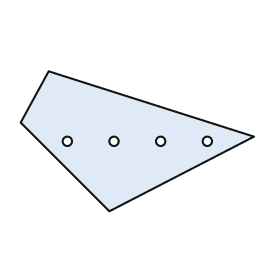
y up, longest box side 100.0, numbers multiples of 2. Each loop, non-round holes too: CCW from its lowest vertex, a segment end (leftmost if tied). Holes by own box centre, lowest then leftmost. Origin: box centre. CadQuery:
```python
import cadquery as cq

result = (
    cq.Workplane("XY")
    .moveTo(-12.0, -30.0)
    .lineTo(50.0, 2.0)
    .lineTo(-38.0, 30.0)
    .lineTo(-50.0, 8.0)
    .close()
    .moveTo(-30.0, 0.0)
    .circle(2.0)
    .moveTo(-10.0, 0.0)
    .circle(2.0)
    .moveTo(10.0, 0.0)
    .circle(2.0)
    .moveTo(30.0, 0.0)
    .circle(2.0)
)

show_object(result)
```